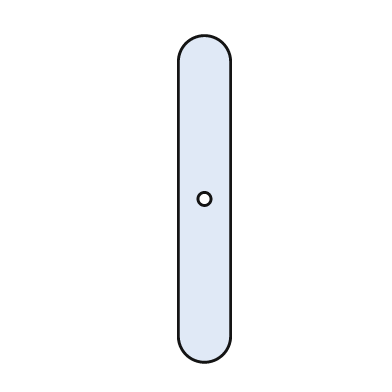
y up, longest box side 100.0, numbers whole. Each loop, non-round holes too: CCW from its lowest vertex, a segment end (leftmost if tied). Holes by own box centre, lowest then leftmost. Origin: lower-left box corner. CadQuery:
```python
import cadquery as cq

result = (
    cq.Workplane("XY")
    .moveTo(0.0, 8.0)
    .threePointArc((8.0, 0.0), (16.0, 8.0))
    .lineTo(16.0, 92.0)
    .threePointArc((8.0, 100.0), (0.0, 92.0))
    .close()
    .moveTo(8.0, 50.0)
    .circle(2.0)
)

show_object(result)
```